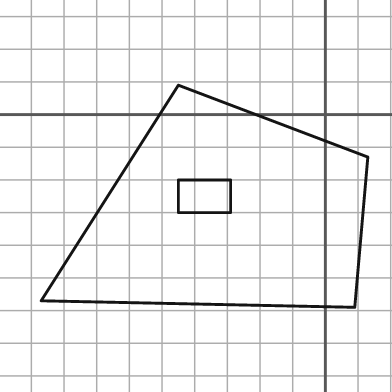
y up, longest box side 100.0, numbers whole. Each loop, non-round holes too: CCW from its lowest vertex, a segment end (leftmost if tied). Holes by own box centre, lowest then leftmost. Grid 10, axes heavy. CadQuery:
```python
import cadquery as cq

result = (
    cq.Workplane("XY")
    .moveTo(9.0, -59.0)
    .lineTo(13.0, -13.0)
    .lineTo(-45.0, 9.0)
    .lineTo(-87.0, -57.0)
    .close()
    .moveTo(-45.0, -30.0)
    .lineTo(-29.0, -30.0)
    .lineTo(-29.0, -20.0)
    .lineTo(-45.0, -20.0)
    .close()
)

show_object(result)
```